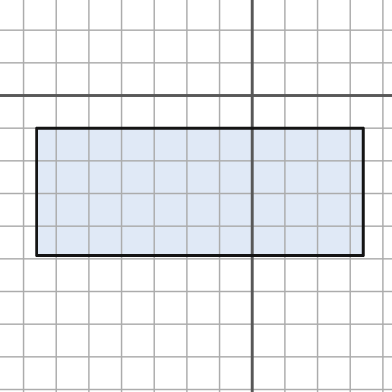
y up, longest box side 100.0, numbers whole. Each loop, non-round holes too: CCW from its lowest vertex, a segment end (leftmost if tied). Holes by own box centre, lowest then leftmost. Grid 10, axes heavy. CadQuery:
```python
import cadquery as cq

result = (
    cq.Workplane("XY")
    .moveTo(-66.0, -49.0)
    .lineTo(34.0, -49.0)
    .lineTo(34.0, -10.0)
    .lineTo(-66.0, -10.0)
    .close()
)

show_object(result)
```